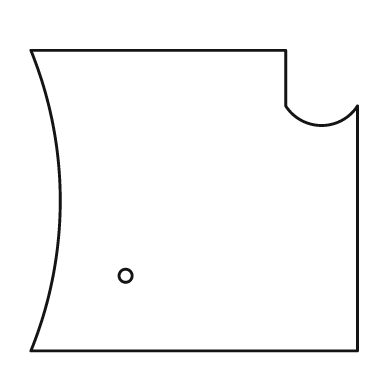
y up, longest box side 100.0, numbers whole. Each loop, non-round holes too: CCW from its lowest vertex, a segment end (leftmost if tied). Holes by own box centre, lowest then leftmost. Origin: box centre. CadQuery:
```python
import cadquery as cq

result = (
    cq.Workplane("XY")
    .moveTo(-50.0, -46.0)
    .lineTo(50.0, -46.0)
    .lineTo(50.0, 29.0)
    .threePointArc((39.0, 23.0), (28.0, 29.0))
    .lineTo(28.0, 46.0)
    .lineTo(-50.0, 46.0)
    .threePointArc((-41.0, 0.0), (-50.0, -46.0))
    .close()
    .moveTo(-21.0, -23.0)
    .circle(2.0)
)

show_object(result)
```